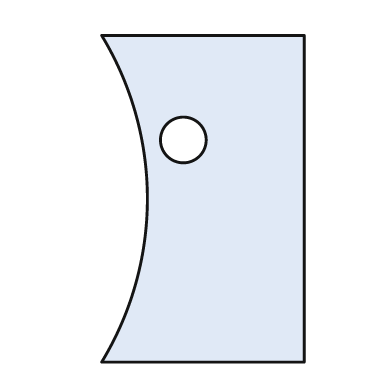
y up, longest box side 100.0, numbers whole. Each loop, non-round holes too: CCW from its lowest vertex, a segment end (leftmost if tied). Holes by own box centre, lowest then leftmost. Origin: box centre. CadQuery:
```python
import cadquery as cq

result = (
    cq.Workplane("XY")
    .moveTo(-31.0, -50.0)
    .lineTo(31.0, -50.0)
    .lineTo(31.0, 50.0)
    .lineTo(-31.0, 50.0)
    .threePointArc((-17.0, 0.0), (-31.0, -50.0))
    .close()
    .moveTo(-6.0, 18.0)
    .circle(7.0)
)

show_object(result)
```